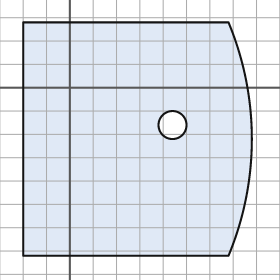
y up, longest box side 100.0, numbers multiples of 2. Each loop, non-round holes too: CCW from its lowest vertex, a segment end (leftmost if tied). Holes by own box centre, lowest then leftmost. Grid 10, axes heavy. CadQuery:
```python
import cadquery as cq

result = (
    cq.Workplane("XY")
    .moveTo(-20.0, -72.0)
    .lineTo(68.0, -72.0)
    .threePointArc((78.0, -22.0), (68.0, 28.0))
    .lineTo(-20.0, 28.0)
    .close()
    .moveTo(44.0, -16.0)
    .circle(6.0)
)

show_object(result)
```